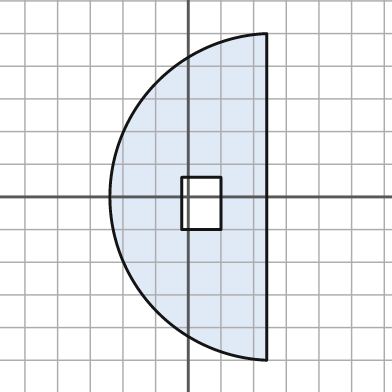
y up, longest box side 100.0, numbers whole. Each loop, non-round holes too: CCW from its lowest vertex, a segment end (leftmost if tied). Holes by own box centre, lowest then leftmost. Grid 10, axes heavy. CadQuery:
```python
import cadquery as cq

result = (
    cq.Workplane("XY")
    .moveTo(24.0, -50.0)
    .lineTo(24.0, 50.0)
    .threePointArc((-24.0, 0.0), (24.0, -50.0))
    .close()
    .moveTo(-2.0, -10.0)
    .lineTo(10.0, -10.0)
    .lineTo(10.0, 6.0)
    .lineTo(-2.0, 6.0)
    .close()
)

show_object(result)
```